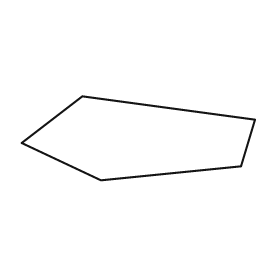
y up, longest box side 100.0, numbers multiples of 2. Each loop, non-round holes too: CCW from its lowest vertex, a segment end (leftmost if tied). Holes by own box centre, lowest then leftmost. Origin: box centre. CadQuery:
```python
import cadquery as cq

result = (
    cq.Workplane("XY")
    .moveTo(-16.0, -18.0)
    .lineTo(44.0, -12.0)
    .lineTo(50.0, 8.0)
    .lineTo(-24.0, 18.0)
    .lineTo(-50.0, -2.0)
    .close()
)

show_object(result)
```